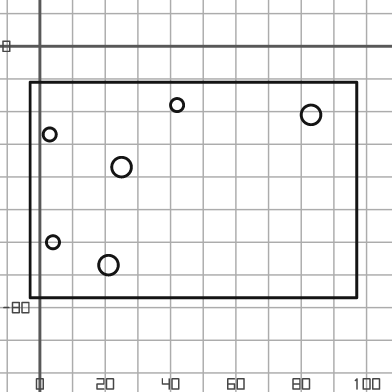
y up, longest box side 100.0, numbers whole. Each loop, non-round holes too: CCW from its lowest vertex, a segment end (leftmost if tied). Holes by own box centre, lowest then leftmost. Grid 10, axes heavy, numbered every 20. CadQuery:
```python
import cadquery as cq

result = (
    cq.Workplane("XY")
    .moveTo(-3.0, -77.0)
    .lineTo(97.0, -77.0)
    .lineTo(97.0, -11.0)
    .lineTo(-3.0, -11.0)
    .close()
    .moveTo(21.0, -67.0)
    .circle(3.0)
    .moveTo(4.0, -60.0)
    .circle(2.0)
    .moveTo(25.0, -37.0)
    .circle(3.0)
    .moveTo(3.0, -27.0)
    .circle(2.0)
    .moveTo(83.0, -21.0)
    .circle(3.0)
    .moveTo(42.0, -18.0)
    .circle(2.0)
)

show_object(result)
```